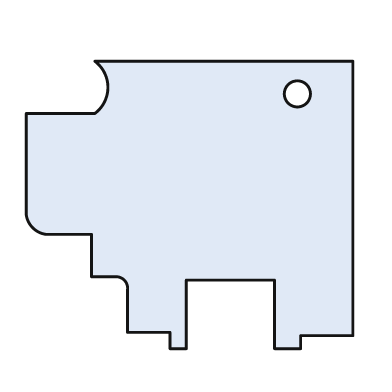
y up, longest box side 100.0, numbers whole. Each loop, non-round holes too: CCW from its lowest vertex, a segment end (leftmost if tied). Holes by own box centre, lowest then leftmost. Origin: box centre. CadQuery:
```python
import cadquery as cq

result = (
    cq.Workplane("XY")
    .moveTo(-6.0, -44.0)
    .lineTo(-1.0, -44.0)
    .lineTo(-1.0, -23.0)
    .lineTo(26.0, -23.0)
    .lineTo(26.0, -44.0)
    .lineTo(34.0, -44.0)
    .lineTo(34.0, -40.0)
    .lineTo(50.0, -40.0)
    .lineTo(50.0, 44.0)
    .lineTo(-29.0, 44.0)
    .threePointArc((-25.0, 36.0), (-29.0, 28.0))
    .lineTo(-50.0, 28.0)
    .lineTo(-50.0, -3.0)
    .threePointArc((-48.0, -7.0), (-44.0, -9.0))
    .lineTo(-30.0, -9.0)
    .lineTo(-30.0, -22.0)
    .lineTo(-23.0, -22.0)
    .threePointArc((-20.0, -23.0), (-19.0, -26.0))
    .lineTo(-19.0, -39.0)
    .lineTo(-6.0, -39.0)
    .close()
    .moveTo(33.0, 34.0)
    .circle(4.0)
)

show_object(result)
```